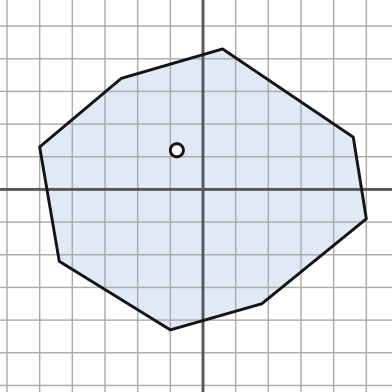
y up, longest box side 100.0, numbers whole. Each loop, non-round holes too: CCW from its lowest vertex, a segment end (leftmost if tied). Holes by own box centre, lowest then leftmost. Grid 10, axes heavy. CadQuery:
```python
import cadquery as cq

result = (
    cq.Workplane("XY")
    .moveTo(-10.0, -43.0)
    .lineTo(18.0, -35.0)
    .lineTo(50.0, -9.0)
    .lineTo(46.0, 16.0)
    .lineTo(6.0, 43.0)
    .lineTo(-25.0, 34.0)
    .lineTo(-50.0, 13.0)
    .lineTo(-44.0, -22.0)
    .close()
    .moveTo(-8.0, 12.0)
    .circle(2.0)
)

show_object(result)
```